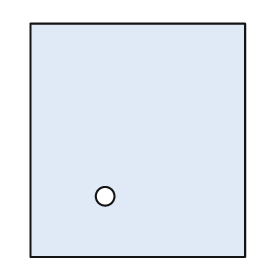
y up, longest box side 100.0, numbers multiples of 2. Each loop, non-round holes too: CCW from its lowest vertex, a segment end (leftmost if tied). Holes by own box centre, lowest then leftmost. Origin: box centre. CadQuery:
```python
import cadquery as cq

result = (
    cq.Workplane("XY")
    .moveTo(-46.0, -50.0)
    .lineTo(46.0, -50.0)
    .lineTo(46.0, 50.0)
    .lineTo(-46.0, 50.0)
    .close()
    .moveTo(-14.0, -24.0)
    .circle(4.0)
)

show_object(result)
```